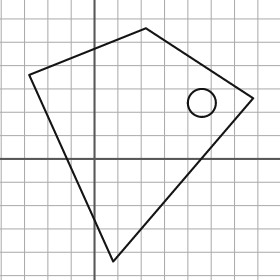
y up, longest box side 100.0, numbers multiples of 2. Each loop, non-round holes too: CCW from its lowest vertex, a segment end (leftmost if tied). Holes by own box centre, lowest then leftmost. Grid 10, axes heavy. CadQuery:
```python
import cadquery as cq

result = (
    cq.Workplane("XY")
    .moveTo(8.0, -44.0)
    .lineTo(68.0, 26.0)
    .lineTo(22.0, 56.0)
    .lineTo(-28.0, 36.0)
    .close()
    .moveTo(46.0, 24.0)
    .circle(6.0)
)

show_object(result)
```